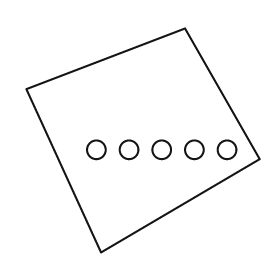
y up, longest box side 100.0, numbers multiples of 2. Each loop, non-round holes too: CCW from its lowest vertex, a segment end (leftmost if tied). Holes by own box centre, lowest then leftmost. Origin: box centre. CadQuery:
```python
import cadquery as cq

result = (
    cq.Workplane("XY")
    .moveTo(-18.0, -48.0)
    .lineTo(50.0, -8.0)
    .lineTo(18.0, 48.0)
    .lineTo(-50.0, 22.0)
    .close()
    .moveTo(-20.0, -4.0)
    .circle(4.0)
    .moveTo(-6.0, -4.0)
    .circle(4.0)
    .moveTo(8.0, -4.0)
    .circle(4.0)
    .moveTo(22.0, -4.0)
    .circle(4.0)
    .moveTo(36.0, -4.0)
    .circle(4.0)
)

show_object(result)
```